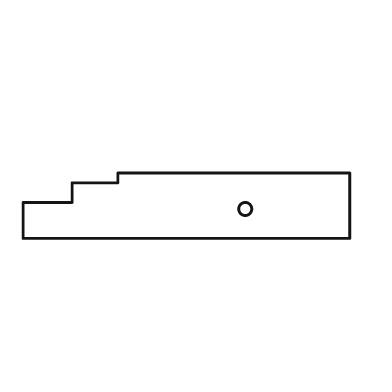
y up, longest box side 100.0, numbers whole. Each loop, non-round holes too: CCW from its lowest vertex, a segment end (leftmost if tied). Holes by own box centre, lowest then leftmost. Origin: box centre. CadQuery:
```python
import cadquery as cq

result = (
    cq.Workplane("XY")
    .moveTo(-50.0, -10.0)
    .lineTo(50.0, -10.0)
    .lineTo(50.0, 10.0)
    .lineTo(-21.0, 10.0)
    .lineTo(-21.0, 7.0)
    .lineTo(-35.0, 7.0)
    .lineTo(-35.0, 1.0)
    .lineTo(-50.0, 1.0)
    .close()
    .moveTo(18.0, -1.0)
    .circle(2.0)
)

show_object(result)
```